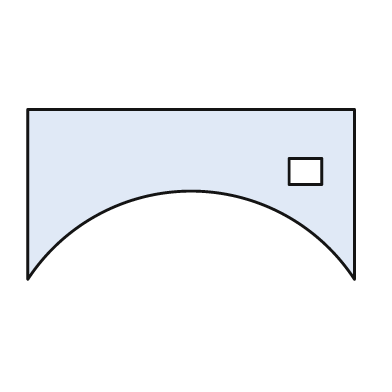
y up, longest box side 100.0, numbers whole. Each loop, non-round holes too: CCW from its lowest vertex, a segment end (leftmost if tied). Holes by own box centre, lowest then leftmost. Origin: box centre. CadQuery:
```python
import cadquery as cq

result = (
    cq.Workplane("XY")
    .moveTo(-50.0, -26.0)
    .threePointArc((0.0, 1.0), (50.0, -26.0))
    .lineTo(50.0, 26.0)
    .lineTo(-50.0, 26.0)
    .close()
    .moveTo(30.0, 3.0)
    .lineTo(40.0, 3.0)
    .lineTo(40.0, 11.0)
    .lineTo(30.0, 11.0)
    .close()
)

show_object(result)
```